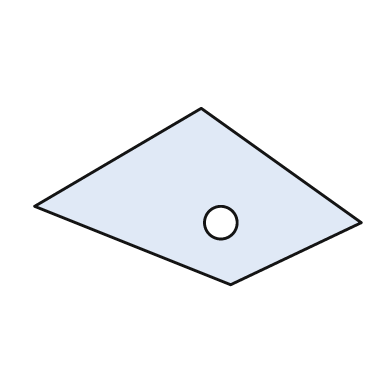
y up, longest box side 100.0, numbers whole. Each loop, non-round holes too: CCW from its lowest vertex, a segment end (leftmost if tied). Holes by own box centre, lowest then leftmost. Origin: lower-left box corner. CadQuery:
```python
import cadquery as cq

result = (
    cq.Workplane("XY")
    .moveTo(60.0, 0.0)
    .lineTo(100.0, 19.0)
    .lineTo(51.0, 54.0)
    .lineTo(0.0, 24.0)
    .close()
    .moveTo(57.0, 19.0)
    .circle(5.0)
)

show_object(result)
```